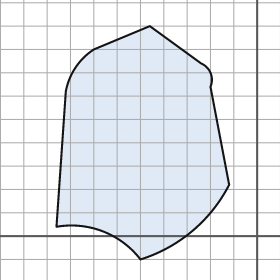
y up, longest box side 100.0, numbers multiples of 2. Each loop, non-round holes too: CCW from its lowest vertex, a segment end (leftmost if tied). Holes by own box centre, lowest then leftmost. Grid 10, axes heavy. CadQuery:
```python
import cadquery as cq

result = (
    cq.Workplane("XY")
    .moveTo(-50.0, -10.0)
    .threePointArc((-28.0, 2.0), (-12.0, 22.0))
    .lineTo(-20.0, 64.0)
    .threePointArc((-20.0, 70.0), (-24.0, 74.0))
    .lineTo(-46.0, 90.0)
    .lineTo(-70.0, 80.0)
    .threePointArc((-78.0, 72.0), (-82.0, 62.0))
    .lineTo(-86.0, 4.0)
    .threePointArc((-66.0, 2.0), (-50.0, -10.0))
    .close()
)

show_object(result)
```